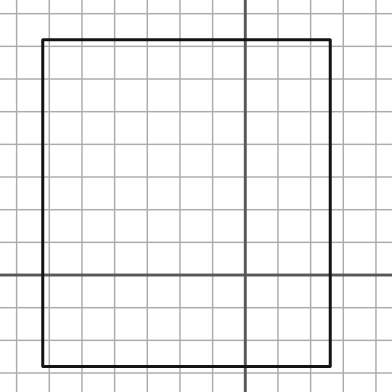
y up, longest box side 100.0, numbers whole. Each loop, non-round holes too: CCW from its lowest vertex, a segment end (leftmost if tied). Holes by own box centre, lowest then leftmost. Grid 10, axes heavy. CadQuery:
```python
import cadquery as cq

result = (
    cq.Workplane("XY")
    .moveTo(-62.0, -28.0)
    .lineTo(26.0, -28.0)
    .lineTo(26.0, 72.0)
    .lineTo(-62.0, 72.0)
    .close()
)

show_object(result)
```